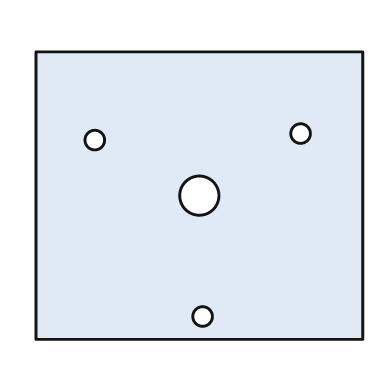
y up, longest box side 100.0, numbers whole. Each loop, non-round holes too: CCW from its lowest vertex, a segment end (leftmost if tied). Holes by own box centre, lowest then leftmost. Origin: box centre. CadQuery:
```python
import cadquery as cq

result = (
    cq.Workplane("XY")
    .moveTo(-50.0, -44.0)
    .lineTo(50.0, -44.0)
    .lineTo(50.0, 44.0)
    .lineTo(-50.0, 44.0)
    .close()
    .moveTo(1.0, -37.0)
    .circle(3.0)
    .moveTo(0.0, 0.0)
    .circle(6.0)
    .moveTo(-32.0, 17.0)
    .circle(3.0)
    .moveTo(31.0, 19.0)
    .circle(3.0)
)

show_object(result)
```